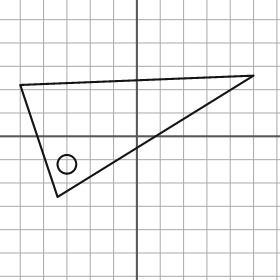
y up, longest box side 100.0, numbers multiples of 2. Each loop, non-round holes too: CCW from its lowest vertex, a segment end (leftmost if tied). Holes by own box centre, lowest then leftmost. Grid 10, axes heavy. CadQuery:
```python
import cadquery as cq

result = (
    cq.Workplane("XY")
    .moveTo(-34.0, -26.0)
    .lineTo(50.0, 26.0)
    .lineTo(-50.0, 22.0)
    .close()
    .moveTo(-30.0, -12.0)
    .circle(4.0)
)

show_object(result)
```